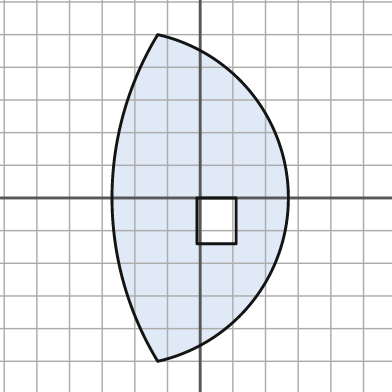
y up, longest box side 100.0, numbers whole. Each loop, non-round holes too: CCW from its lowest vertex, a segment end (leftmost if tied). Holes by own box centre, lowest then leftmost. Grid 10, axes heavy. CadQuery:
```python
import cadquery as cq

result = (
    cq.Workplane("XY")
    .moveTo(-13.0, -50.0)
    .threePointArc((27.0, 0.0), (-13.0, 50.0))
    .threePointArc((-27.0, 0.0), (-13.0, -50.0))
    .close()
    .moveTo(-1.0, -14.0)
    .lineTo(11.0, -14.0)
    .lineTo(11.0, 0.0)
    .lineTo(-1.0, 0.0)
    .close()
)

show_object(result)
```